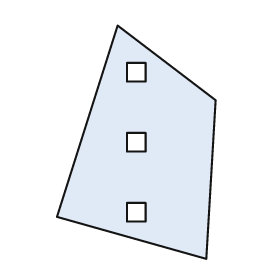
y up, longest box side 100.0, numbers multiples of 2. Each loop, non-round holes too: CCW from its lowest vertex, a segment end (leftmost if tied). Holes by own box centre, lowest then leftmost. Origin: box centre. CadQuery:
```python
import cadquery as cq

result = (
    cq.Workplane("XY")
    .moveTo(30.0, -50.0)
    .lineTo(34.0, 18.0)
    .lineTo(-8.0, 50.0)
    .lineTo(-34.0, -32.0)
    .close()
    .moveTo(-4.0, -34.0)
    .lineTo(4.0, -34.0)
    .lineTo(4.0, -26.0)
    .lineTo(-4.0, -26.0)
    .close()
    .moveTo(-4.0, -4.0)
    .lineTo(4.0, -4.0)
    .lineTo(4.0, 4.0)
    .lineTo(-4.0, 4.0)
    .close()
    .moveTo(-4.0, 26.0)
    .lineTo(4.0, 26.0)
    .lineTo(4.0, 34.0)
    .lineTo(-4.0, 34.0)
    .close()
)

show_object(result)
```